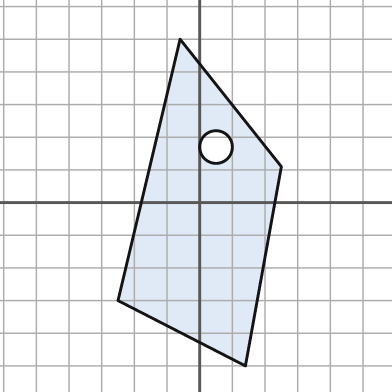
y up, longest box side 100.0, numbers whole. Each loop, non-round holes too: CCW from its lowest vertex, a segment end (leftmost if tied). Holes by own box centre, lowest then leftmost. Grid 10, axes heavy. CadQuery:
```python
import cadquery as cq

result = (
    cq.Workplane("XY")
    .moveTo(14.0, -50.0)
    .lineTo(25.0, 11.0)
    .lineTo(-6.0, 50.0)
    .lineTo(-25.0, -30.0)
    .close()
    .moveTo(5.0, 17.0)
    .circle(5.0)
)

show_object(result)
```